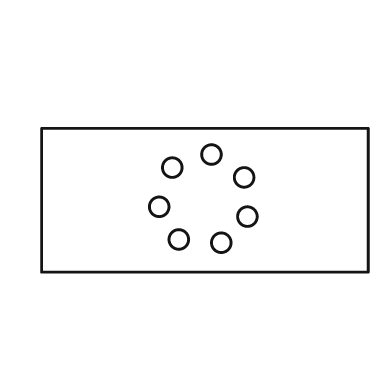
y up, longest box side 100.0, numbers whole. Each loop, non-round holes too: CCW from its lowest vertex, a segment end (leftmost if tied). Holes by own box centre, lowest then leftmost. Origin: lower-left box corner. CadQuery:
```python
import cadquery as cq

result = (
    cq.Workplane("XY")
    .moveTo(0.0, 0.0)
    .lineTo(100.0, 0.0)
    .lineTo(100.0, 44.0)
    .lineTo(0.0, 44.0)
    .close()
    .moveTo(55.0, 9.0)
    .circle(3.0)
    .moveTo(42.0, 10.0)
    .circle(3.0)
    .moveTo(63.0, 17.0)
    .circle(3.0)
    .moveTo(36.0, 20.0)
    .circle(3.0)
    .moveTo(62.0, 29.0)
    .circle(3.0)
    .moveTo(40.0, 32.0)
    .circle(3.0)
    .moveTo(52.0, 36.0)
    .circle(3.0)
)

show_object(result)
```